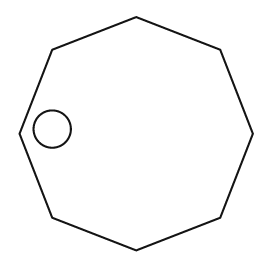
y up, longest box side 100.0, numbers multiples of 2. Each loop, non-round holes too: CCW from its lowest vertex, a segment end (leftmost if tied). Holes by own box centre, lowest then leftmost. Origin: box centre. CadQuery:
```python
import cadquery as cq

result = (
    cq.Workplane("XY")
    .moveTo(0.0, -50.0)
    .lineTo(36.0, -36.0)
    .lineTo(50.0, 0.0)
    .lineTo(36.0, 36.0)
    .lineTo(0.0, 50.0)
    .lineTo(-36.0, 36.0)
    .lineTo(-50.0, 0.0)
    .lineTo(-36.0, -36.0)
    .close()
    .moveTo(-36.0, 2.0)
    .circle(8.0)
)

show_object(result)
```